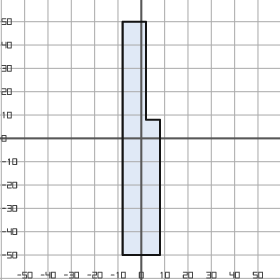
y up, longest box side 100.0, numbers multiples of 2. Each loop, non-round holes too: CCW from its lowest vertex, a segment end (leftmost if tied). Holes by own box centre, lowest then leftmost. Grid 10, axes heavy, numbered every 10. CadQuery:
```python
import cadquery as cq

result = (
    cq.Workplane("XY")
    .moveTo(-8.0, -50.0)
    .lineTo(8.0, -50.0)
    .lineTo(8.0, 8.0)
    .lineTo(2.0, 8.0)
    .lineTo(2.0, 50.0)
    .lineTo(-8.0, 50.0)
    .close()
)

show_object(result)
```